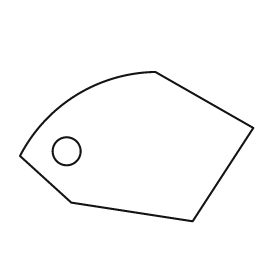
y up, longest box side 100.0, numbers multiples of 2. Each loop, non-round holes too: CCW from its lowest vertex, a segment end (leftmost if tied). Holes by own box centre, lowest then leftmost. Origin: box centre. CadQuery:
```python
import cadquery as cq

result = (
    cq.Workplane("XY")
    .moveTo(24.0, -32.0)
    .lineTo(50.0, 8.0)
    .lineTo(8.0, 32.0)
    .threePointArc((-26.0, 22.0), (-50.0, -4.0))
    .lineTo(-28.0, -24.0)
    .close()
    .moveTo(-30.0, -2.0)
    .circle(6.0)
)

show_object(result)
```